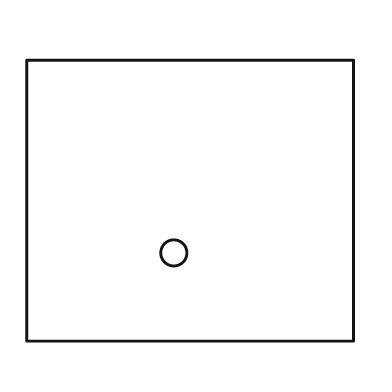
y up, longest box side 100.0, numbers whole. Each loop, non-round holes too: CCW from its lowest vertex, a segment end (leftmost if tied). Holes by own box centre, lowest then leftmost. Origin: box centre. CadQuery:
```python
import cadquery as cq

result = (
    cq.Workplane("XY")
    .moveTo(-50.0, -43.0)
    .lineTo(50.0, -43.0)
    .lineTo(50.0, 43.0)
    .lineTo(-50.0, 43.0)
    .close()
    .moveTo(-5.0, -16.0)
    .circle(4.0)
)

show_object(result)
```